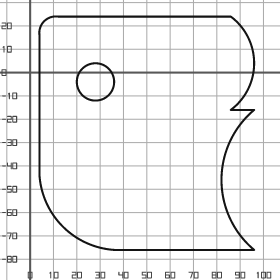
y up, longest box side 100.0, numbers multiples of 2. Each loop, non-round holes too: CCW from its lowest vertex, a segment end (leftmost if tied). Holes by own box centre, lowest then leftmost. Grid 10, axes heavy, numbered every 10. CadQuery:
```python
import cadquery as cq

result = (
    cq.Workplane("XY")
    .moveTo(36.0, -76.0)
    .lineTo(96.0, -76.0)
    .threePointArc((82.0, -46.0), (96.0, -16.0))
    .lineTo(86.0, -16.0)
    .threePointArc((96.0, 4.0), (86.0, 24.0))
    .lineTo(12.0, 24.0)
    .threePointArc((6.0, 22.0), (4.0, 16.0))
    .lineTo(4.0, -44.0)
    .threePointArc((14.0, -66.0), (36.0, -76.0))
    .close()
    .moveTo(28.0, -4.0)
    .circle(8.0)
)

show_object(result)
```